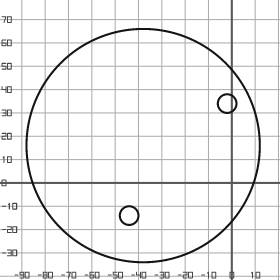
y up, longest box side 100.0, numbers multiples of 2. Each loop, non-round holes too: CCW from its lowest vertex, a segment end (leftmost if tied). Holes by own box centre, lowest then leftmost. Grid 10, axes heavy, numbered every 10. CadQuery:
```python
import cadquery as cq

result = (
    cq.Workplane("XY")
    .moveTo(-38.0, 16.0)
    .circle(50.0)
    .moveTo(-44.0, -14.0)
    .circle(4.0)
    .moveTo(-2.0, 34.0)
    .circle(4.0)
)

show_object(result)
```